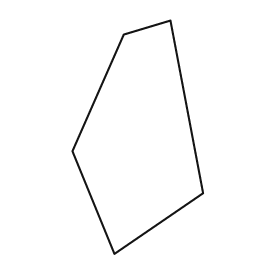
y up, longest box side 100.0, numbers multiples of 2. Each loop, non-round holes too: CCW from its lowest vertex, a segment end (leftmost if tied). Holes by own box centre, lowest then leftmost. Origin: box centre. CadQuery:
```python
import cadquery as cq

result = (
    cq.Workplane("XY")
    .moveTo(-10.0, -50.0)
    .lineTo(28.0, -24.0)
    .lineTo(14.0, 50.0)
    .lineTo(-6.0, 44.0)
    .lineTo(-28.0, -6.0)
    .close()
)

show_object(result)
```